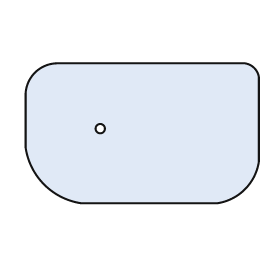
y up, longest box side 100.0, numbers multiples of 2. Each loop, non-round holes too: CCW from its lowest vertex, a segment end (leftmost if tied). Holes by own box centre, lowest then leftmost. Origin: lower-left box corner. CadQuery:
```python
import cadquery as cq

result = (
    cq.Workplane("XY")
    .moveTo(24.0, 0.0)
    .lineTo(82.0, 0.0)
    .threePointArc((94.0, 6.0), (100.0, 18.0))
    .lineTo(100.0, 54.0)
    .threePointArc((98.0, 58.0), (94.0, 60.0))
    .lineTo(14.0, 60.0)
    .threePointArc((4.0, 56.0), (0.0, 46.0))
    .lineTo(0.0, 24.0)
    .threePointArc((8.0, 8.0), (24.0, 0.0))
    .close()
    .moveTo(32.0, 32.0)
    .circle(2.0)
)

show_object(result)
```